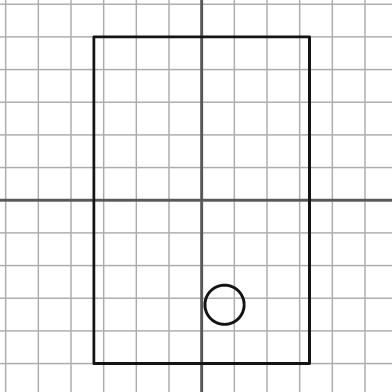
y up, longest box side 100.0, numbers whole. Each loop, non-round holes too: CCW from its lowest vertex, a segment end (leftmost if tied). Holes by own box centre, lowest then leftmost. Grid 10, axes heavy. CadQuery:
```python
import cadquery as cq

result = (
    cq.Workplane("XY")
    .moveTo(-33.0, -50.0)
    .lineTo(33.0, -50.0)
    .lineTo(33.0, 50.0)
    .lineTo(-33.0, 50.0)
    .close()
    .moveTo(7.0, -32.0)
    .circle(6.0)
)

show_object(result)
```